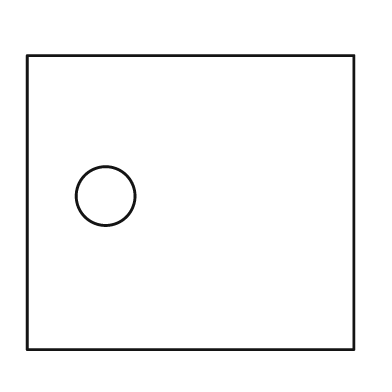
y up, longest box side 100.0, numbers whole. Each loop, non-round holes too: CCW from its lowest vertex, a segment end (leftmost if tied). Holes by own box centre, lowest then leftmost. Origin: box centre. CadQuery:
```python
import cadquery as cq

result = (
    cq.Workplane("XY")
    .moveTo(-50.0, -45.0)
    .lineTo(50.0, -45.0)
    .lineTo(50.0, 45.0)
    .lineTo(-50.0, 45.0)
    .close()
    .moveTo(-26.0, 2.0)
    .circle(9.0)
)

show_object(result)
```